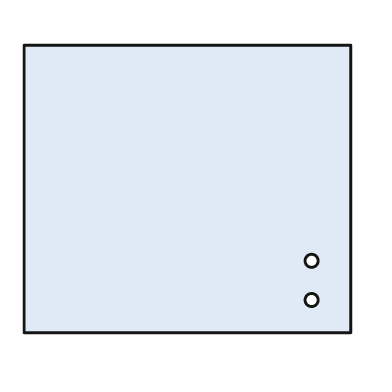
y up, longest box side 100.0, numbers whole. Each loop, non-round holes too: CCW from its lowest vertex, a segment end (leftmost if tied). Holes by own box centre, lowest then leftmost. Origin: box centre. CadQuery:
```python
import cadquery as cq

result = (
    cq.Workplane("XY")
    .moveTo(-50.0, -44.0)
    .lineTo(50.0, -44.0)
    .lineTo(50.0, 44.0)
    .lineTo(-50.0, 44.0)
    .close()
    .moveTo(38.0, -34.0)
    .circle(2.0)
    .moveTo(38.0, -22.0)
    .circle(2.0)
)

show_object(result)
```